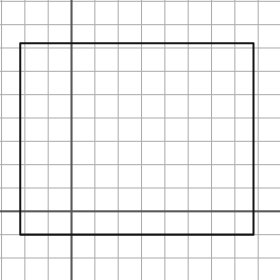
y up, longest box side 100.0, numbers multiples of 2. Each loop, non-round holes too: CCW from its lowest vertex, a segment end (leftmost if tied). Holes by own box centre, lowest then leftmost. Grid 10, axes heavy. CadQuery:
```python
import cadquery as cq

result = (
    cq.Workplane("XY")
    .moveTo(-22.0, -10.0)
    .lineTo(78.0, -10.0)
    .lineTo(78.0, 72.0)
    .lineTo(-22.0, 72.0)
    .close()
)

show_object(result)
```